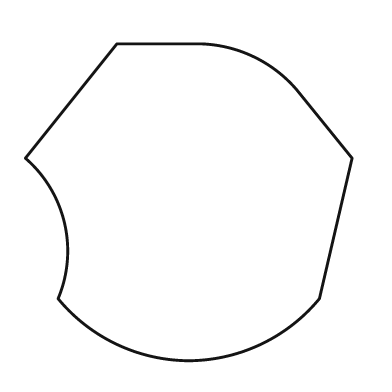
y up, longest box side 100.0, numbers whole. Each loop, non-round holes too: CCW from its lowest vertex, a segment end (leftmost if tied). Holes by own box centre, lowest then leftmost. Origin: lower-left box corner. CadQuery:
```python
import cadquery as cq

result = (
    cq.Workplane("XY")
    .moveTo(50.0, 0.0)
    .threePointArc((72.0, 5.0), (90.0, 19.0))
    .lineTo(100.0, 62.0)
    .lineTo(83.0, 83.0)
    .threePointArc((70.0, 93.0), (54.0, 97.0))
    .lineTo(28.0, 97.0)
    .lineTo(0.0, 62.0)
    .threePointArc((12.0, 42.0), (10.0, 19.0))
    .threePointArc((28.0, 5.0), (50.0, 0.0))
    .close()
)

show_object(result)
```